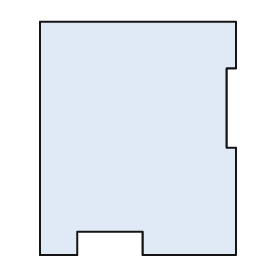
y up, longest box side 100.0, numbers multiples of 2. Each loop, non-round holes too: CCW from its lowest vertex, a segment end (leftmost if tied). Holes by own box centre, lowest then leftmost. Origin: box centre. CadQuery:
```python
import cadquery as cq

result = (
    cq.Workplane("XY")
    .moveTo(-42.0, -50.0)
    .lineTo(-26.0, -50.0)
    .lineTo(-26.0, -40.0)
    .lineTo(2.0, -40.0)
    .lineTo(2.0, -50.0)
    .lineTo(42.0, -50.0)
    .lineTo(42.0, -4.0)
    .lineTo(38.0, -4.0)
    .lineTo(38.0, 30.0)
    .lineTo(42.0, 30.0)
    .lineTo(42.0, 50.0)
    .lineTo(-42.0, 50.0)
    .close()
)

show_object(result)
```